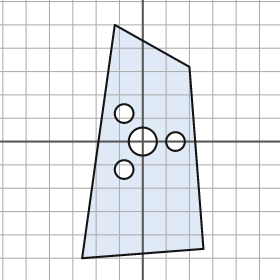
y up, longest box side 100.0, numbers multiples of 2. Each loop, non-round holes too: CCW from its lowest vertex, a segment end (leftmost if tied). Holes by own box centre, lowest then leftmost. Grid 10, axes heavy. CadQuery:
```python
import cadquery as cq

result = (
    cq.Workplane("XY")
    .moveTo(-26.0, -50.0)
    .lineTo(26.0, -46.0)
    .lineTo(20.0, 32.0)
    .lineTo(-12.0, 50.0)
    .close()
    .moveTo(-8.0, -12.0)
    .circle(4.0)
    .moveTo(0.0, 0.0)
    .circle(6.0)
    .moveTo(14.0, 0.0)
    .circle(4.0)
    .moveTo(-8.0, 12.0)
    .circle(4.0)
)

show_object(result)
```